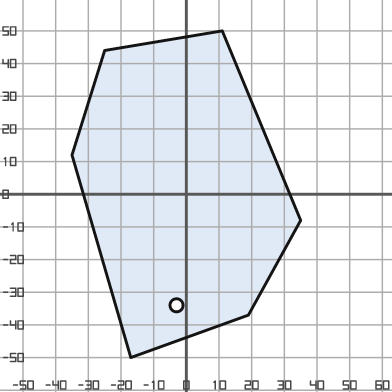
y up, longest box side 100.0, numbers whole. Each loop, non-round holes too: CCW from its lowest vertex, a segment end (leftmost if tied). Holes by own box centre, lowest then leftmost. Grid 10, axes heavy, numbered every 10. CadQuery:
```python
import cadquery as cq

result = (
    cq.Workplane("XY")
    .moveTo(-17.0, -50.0)
    .lineTo(19.0, -37.0)
    .lineTo(35.0, -8.0)
    .lineTo(11.0, 50.0)
    .lineTo(-25.0, 44.0)
    .lineTo(-35.0, 12.0)
    .close()
    .moveTo(-3.0, -34.0)
    .circle(2.0)
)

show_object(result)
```